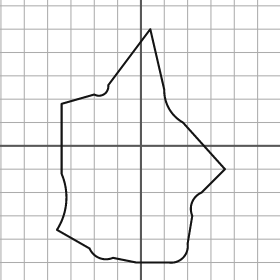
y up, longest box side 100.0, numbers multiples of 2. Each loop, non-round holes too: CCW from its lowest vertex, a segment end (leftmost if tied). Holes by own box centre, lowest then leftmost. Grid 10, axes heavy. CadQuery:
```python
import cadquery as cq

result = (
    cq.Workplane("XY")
    .moveTo(-2.0, -50.0)
    .lineTo(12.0, -50.0)
    .threePointArc((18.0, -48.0), (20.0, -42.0))
    .lineTo(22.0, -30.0)
    .threePointArc((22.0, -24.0), (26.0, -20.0))
    .lineTo(36.0, -10.0)
    .lineTo(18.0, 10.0)
    .threePointArc((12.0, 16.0), (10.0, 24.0))
    .lineTo(4.0, 50.0)
    .lineTo(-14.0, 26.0)
    .threePointArc((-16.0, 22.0), (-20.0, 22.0))
    .lineTo(-34.0, 18.0)
    .lineTo(-34.0, -12.0)
    .threePointArc((-32.0, -24.0), (-36.0, -36.0))
    .lineTo(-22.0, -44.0)
    .threePointArc((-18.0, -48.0), (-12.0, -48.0))
    .close()
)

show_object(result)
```